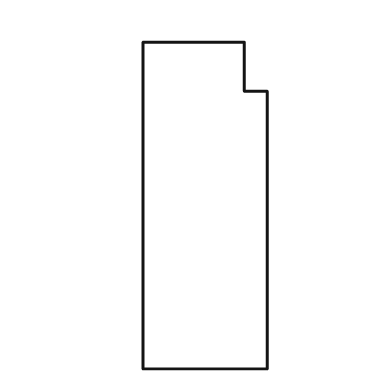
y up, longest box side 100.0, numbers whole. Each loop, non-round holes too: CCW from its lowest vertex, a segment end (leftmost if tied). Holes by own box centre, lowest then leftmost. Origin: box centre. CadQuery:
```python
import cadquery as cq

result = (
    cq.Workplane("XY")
    .moveTo(-19.0, -50.0)
    .lineTo(19.0, -50.0)
    .lineTo(19.0, 35.0)
    .lineTo(12.0, 35.0)
    .lineTo(12.0, 50.0)
    .lineTo(-19.0, 50.0)
    .close()
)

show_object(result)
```